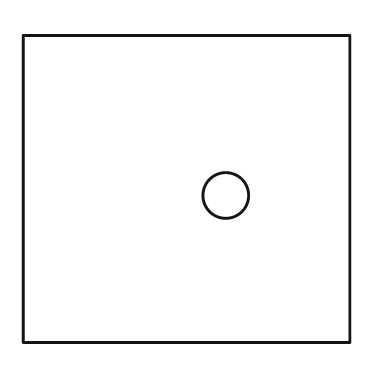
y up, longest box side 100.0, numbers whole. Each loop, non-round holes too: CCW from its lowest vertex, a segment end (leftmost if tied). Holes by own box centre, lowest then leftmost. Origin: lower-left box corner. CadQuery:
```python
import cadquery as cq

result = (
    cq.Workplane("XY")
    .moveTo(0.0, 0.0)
    .lineTo(100.0, 0.0)
    .lineTo(100.0, 94.0)
    .lineTo(0.0, 94.0)
    .close()
    .moveTo(62.0, 45.0)
    .circle(7.0)
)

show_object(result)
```